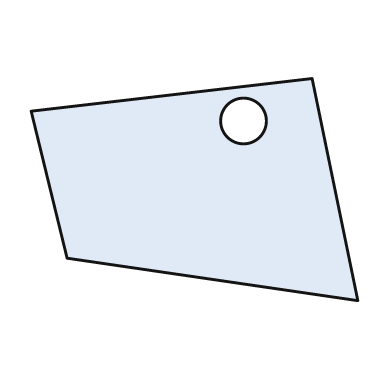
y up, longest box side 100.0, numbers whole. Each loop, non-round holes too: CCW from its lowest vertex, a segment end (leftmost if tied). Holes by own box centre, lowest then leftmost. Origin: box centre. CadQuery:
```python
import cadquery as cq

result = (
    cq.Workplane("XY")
    .moveTo(50.0, -34.0)
    .lineTo(36.0, 34.0)
    .lineTo(-50.0, 24.0)
    .lineTo(-39.0, -21.0)
    .close()
    .moveTo(15.0, 21.0)
    .circle(7.0)
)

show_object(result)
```